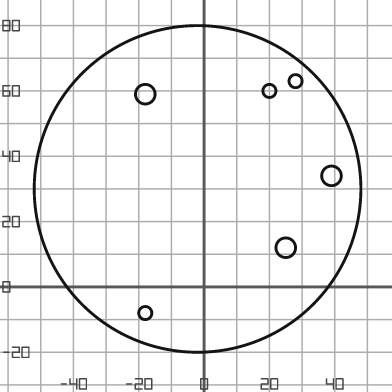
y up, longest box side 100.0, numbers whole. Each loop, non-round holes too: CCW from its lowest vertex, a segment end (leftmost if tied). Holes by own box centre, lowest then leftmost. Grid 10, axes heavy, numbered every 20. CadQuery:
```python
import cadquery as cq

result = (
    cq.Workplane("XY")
    .moveTo(-2.0, 30.0)
    .circle(50.0)
    .moveTo(-18.0, -8.0)
    .circle(2.0)
    .moveTo(25.0, 12.0)
    .circle(3.0)
    .moveTo(39.0, 34.0)
    .circle(3.0)
    .moveTo(-18.0, 59.0)
    .circle(3.0)
    .moveTo(20.0, 60.0)
    .circle(2.0)
    .moveTo(28.0, 63.0)
    .circle(2.0)
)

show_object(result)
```